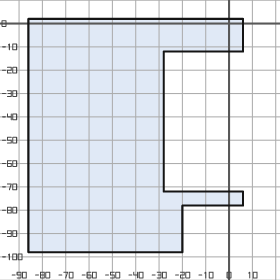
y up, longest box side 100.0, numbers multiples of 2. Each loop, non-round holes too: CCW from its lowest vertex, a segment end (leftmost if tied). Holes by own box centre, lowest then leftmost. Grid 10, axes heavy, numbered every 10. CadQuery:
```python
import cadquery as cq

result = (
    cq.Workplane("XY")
    .moveTo(-86.0, -98.0)
    .lineTo(-20.0, -98.0)
    .lineTo(-20.0, -78.0)
    .lineTo(6.0, -78.0)
    .lineTo(6.0, -72.0)
    .lineTo(-28.0, -72.0)
    .lineTo(-28.0, -12.0)
    .lineTo(6.0, -12.0)
    .lineTo(6.0, 2.0)
    .lineTo(-86.0, 2.0)
    .close()
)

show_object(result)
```